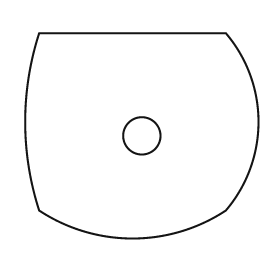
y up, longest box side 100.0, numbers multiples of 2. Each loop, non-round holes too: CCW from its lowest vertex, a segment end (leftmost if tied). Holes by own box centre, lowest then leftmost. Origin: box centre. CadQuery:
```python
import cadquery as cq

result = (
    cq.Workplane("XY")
    .moveTo(-44.0, -32.0)
    .threePointArc((-4.0, -44.0), (36.0, -32.0))
    .threePointArc((50.0, 6.0), (36.0, 44.0))
    .lineTo(-44.0, 44.0)
    .threePointArc((-50.0, 6.0), (-44.0, -32.0))
    .close()
    .moveTo(0.0, 0.0)
    .circle(8.0)
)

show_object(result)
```